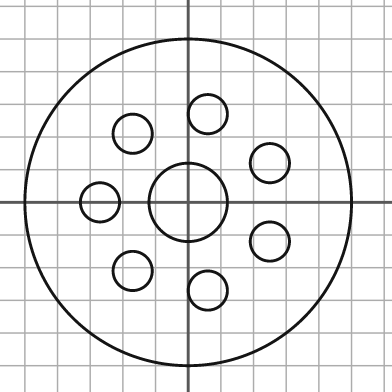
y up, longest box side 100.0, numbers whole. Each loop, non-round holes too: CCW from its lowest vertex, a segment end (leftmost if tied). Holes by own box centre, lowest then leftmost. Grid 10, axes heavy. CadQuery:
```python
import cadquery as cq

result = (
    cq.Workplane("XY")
    .moveTo(0.0, 0.0)
    .circle(50.0)
    .moveTo(6.0, -27.0)
    .circle(6.0)
    .moveTo(-17.0, -21.0)
    .circle(6.0)
    .moveTo(25.0, -12.0)
    .circle(6.0)
    .moveTo(-27.0, 0.0)
    .circle(6.0)
    .moveTo(0.0, 0.0)
    .circle(12.0)
    .moveTo(25.0, 12.0)
    .circle(6.0)
    .moveTo(-17.0, 21.0)
    .circle(6.0)
    .moveTo(6.0, 27.0)
    .circle(6.0)
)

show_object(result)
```